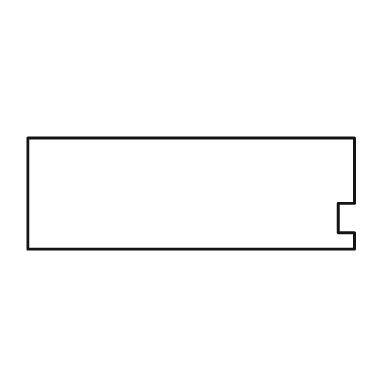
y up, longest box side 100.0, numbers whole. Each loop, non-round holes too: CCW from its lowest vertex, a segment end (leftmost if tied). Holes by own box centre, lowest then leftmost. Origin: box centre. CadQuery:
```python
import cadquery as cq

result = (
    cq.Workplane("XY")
    .moveTo(-50.0, -17.0)
    .lineTo(50.0, -17.0)
    .lineTo(50.0, -12.0)
    .lineTo(45.0, -12.0)
    .lineTo(45.0, -3.0)
    .lineTo(50.0, -3.0)
    .lineTo(50.0, 17.0)
    .lineTo(-50.0, 17.0)
    .close()
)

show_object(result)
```